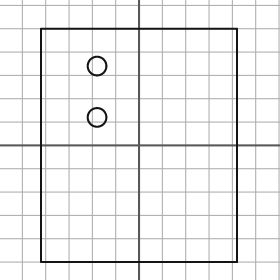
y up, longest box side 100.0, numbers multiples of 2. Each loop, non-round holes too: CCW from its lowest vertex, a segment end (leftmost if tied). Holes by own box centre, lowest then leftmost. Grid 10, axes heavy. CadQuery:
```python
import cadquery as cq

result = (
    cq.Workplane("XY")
    .moveTo(-42.0, -50.0)
    .lineTo(42.0, -50.0)
    .lineTo(42.0, 50.0)
    .lineTo(-42.0, 50.0)
    .close()
    .moveTo(-18.0, 12.0)
    .circle(4.0)
    .moveTo(-18.0, 34.0)
    .circle(4.0)
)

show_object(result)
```